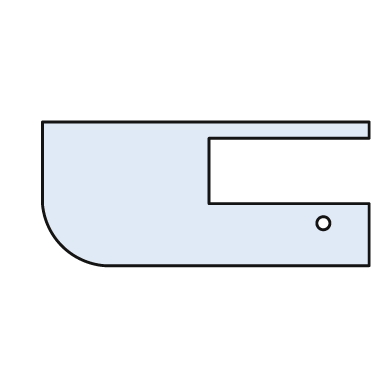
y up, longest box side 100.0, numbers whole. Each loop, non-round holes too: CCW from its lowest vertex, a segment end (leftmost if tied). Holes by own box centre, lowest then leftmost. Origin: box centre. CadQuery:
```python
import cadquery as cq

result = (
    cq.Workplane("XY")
    .moveTo(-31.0, -22.0)
    .lineTo(50.0, -22.0)
    .lineTo(50.0, -3.0)
    .lineTo(1.0, -3.0)
    .lineTo(1.0, 17.0)
    .lineTo(50.0, 17.0)
    .lineTo(50.0, 22.0)
    .lineTo(-50.0, 22.0)
    .lineTo(-50.0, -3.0)
    .threePointArc((-44.0, -16.0), (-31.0, -22.0))
    .close()
    .moveTo(36.0, -9.0)
    .circle(2.0)
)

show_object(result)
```